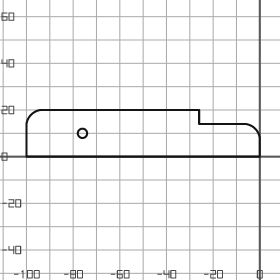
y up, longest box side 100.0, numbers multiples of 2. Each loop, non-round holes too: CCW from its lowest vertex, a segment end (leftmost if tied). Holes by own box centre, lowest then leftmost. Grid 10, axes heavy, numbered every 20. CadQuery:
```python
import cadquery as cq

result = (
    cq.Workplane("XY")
    .moveTo(-100.0, 0.0)
    .lineTo(0.0, 0.0)
    .lineTo(0.0, 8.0)
    .threePointArc((-2.0, 12.0), (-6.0, 14.0))
    .lineTo(-26.0, 14.0)
    .lineTo(-26.0, 20.0)
    .lineTo(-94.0, 20.0)
    .threePointArc((-98.0, 18.0), (-100.0, 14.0))
    .close()
    .moveTo(-76.0, 10.0)
    .circle(2.0)
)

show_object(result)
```